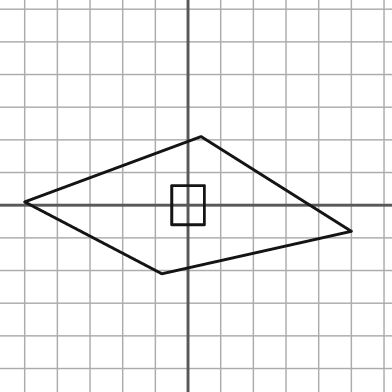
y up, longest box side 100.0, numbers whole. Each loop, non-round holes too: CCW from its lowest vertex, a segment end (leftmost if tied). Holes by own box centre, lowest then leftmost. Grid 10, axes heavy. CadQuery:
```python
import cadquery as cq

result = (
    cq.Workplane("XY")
    .moveTo(-8.0, -21.0)
    .lineTo(50.0, -8.0)
    .lineTo(4.0, 21.0)
    .lineTo(-50.0, 1.0)
    .close()
    .moveTo(-5.0, -6.0)
    .lineTo(5.0, -6.0)
    .lineTo(5.0, 6.0)
    .lineTo(-5.0, 6.0)
    .close()
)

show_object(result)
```